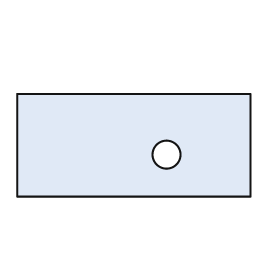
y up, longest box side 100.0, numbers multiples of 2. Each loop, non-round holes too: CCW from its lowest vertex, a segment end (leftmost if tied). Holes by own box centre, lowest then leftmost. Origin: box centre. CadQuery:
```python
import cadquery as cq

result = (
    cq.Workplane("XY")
    .moveTo(-50.0, -22.0)
    .lineTo(50.0, -22.0)
    .lineTo(50.0, 22.0)
    .lineTo(-50.0, 22.0)
    .close()
    .moveTo(14.0, -4.0)
    .circle(6.0)
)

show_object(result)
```